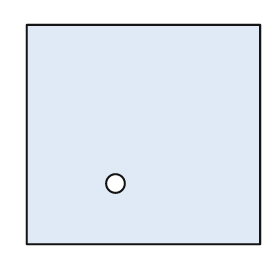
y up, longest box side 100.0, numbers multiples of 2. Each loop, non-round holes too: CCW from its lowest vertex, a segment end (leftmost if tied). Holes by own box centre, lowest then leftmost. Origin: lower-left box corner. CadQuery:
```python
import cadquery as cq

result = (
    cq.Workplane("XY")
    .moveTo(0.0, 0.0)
    .lineTo(100.0, 0.0)
    .lineTo(100.0, 94.0)
    .lineTo(0.0, 94.0)
    .close()
    .moveTo(38.0, 26.0)
    .circle(4.0)
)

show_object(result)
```